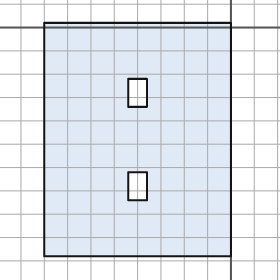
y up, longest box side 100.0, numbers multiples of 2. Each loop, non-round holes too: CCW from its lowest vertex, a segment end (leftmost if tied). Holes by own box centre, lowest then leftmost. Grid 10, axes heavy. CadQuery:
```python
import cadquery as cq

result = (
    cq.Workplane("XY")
    .moveTo(-80.0, -98.0)
    .lineTo(0.0, -98.0)
    .lineTo(0.0, 2.0)
    .lineTo(-80.0, 2.0)
    .close()
    .moveTo(-44.0, -74.0)
    .lineTo(-36.0, -74.0)
    .lineTo(-36.0, -62.0)
    .lineTo(-44.0, -62.0)
    .close()
    .moveTo(-44.0, -34.0)
    .lineTo(-36.0, -34.0)
    .lineTo(-36.0, -22.0)
    .lineTo(-44.0, -22.0)
    .close()
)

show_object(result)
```